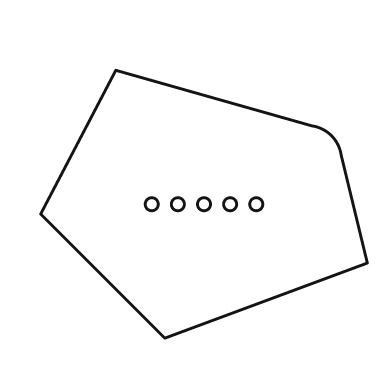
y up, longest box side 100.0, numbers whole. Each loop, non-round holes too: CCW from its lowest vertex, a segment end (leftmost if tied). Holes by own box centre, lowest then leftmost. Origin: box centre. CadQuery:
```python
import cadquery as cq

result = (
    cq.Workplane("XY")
    .moveTo(-12.0, -41.0)
    .lineTo(50.0, -18.0)
    .lineTo(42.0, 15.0)
    .threePointArc((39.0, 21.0), (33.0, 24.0))
    .lineTo(-27.0, 41.0)
    .lineTo(-50.0, -3.0)
    .close()
    .moveTo(-16.0, 0.0)
    .circle(2.0)
    .moveTo(-8.0, 0.0)
    .circle(2.0)
    .moveTo(0.0, 0.0)
    .circle(2.0)
    .moveTo(8.0, 0.0)
    .circle(2.0)
    .moveTo(16.0, 0.0)
    .circle(2.0)
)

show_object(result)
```